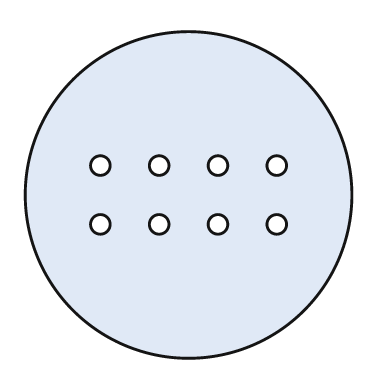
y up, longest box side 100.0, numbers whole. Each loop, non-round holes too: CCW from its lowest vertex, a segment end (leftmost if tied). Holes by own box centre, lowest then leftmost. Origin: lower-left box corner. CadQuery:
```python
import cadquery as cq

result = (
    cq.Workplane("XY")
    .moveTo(50.0, 50.0)
    .circle(50.0)
    .moveTo(23.0, 41.0)
    .circle(3.0)
    .moveTo(41.0, 41.0)
    .circle(3.0)
    .moveTo(59.0, 41.0)
    .circle(3.0)
    .moveTo(77.0, 41.0)
    .circle(3.0)
    .moveTo(23.0, 59.0)
    .circle(3.0)
    .moveTo(41.0, 59.0)
    .circle(3.0)
    .moveTo(59.0, 59.0)
    .circle(3.0)
    .moveTo(77.0, 59.0)
    .circle(3.0)
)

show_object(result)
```